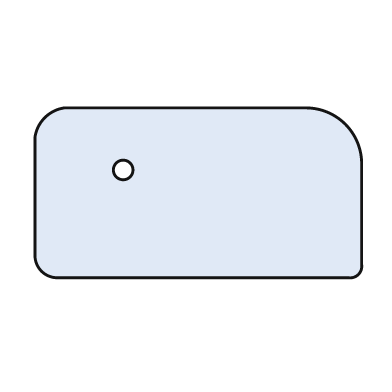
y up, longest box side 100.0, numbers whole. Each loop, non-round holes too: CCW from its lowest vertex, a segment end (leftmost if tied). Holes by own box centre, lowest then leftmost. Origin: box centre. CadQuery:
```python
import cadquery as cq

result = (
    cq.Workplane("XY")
    .moveTo(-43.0, -26.0)
    .lineTo(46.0, -26.0)
    .threePointArc((49.0, -25.0), (50.0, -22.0))
    .lineTo(50.0, 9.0)
    .threePointArc((45.0, 21.0), (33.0, 26.0))
    .lineTo(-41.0, 26.0)
    .threePointArc((-47.0, 23.0), (-50.0, 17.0))
    .lineTo(-50.0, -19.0)
    .threePointArc((-48.0, -24.0), (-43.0, -26.0))
    .close()
    .moveTo(-23.0, 7.0)
    .circle(3.0)
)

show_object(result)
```